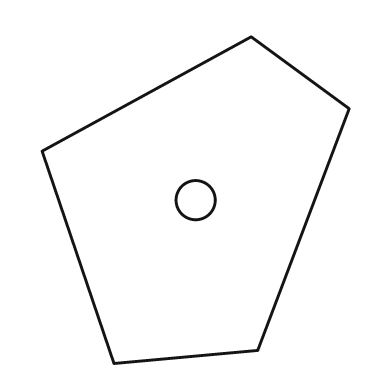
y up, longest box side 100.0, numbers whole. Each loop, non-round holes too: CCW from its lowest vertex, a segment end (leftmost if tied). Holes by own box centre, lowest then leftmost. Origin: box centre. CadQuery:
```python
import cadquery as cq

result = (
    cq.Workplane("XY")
    .moveTo(-25.0, -50.0)
    .lineTo(19.0, -46.0)
    .lineTo(47.0, 28.0)
    .lineTo(17.0, 50.0)
    .lineTo(-47.0, 15.0)
    .close()
    .moveTo(0.0, 0.0)
    .circle(6.0)
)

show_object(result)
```